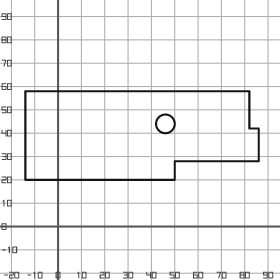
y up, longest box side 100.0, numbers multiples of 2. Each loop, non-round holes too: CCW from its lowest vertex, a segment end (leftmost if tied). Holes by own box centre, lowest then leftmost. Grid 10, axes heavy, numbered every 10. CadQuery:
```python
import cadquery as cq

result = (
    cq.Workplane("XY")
    .moveTo(-14.0, 20.0)
    .lineTo(50.0, 20.0)
    .lineTo(50.0, 28.0)
    .lineTo(86.0, 28.0)
    .lineTo(86.0, 42.0)
    .lineTo(82.0, 42.0)
    .lineTo(82.0, 58.0)
    .lineTo(-14.0, 58.0)
    .close()
    .moveTo(46.0, 44.0)
    .circle(4.0)
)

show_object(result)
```